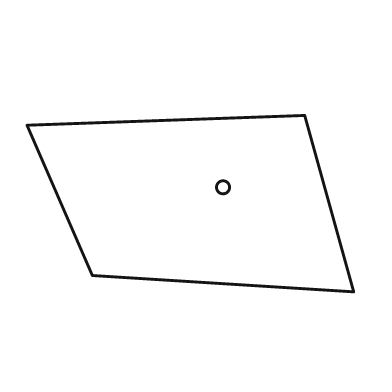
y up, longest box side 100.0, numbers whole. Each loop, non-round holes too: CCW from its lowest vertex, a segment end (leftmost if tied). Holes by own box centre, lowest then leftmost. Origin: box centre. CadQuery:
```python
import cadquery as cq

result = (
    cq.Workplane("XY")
    .moveTo(50.0, -27.0)
    .lineTo(35.0, 27.0)
    .lineTo(-50.0, 24.0)
    .lineTo(-30.0, -22.0)
    .close()
    .moveTo(10.0, 5.0)
    .circle(2.0)
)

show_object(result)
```